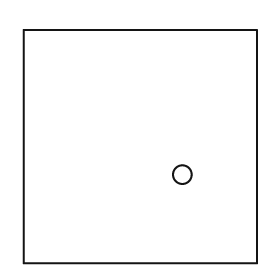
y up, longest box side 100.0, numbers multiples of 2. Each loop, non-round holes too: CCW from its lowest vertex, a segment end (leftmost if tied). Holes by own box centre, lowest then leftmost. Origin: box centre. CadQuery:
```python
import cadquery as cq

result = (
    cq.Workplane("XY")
    .moveTo(-50.0, -50.0)
    .lineTo(50.0, -50.0)
    .lineTo(50.0, 50.0)
    .lineTo(-50.0, 50.0)
    .close()
    .moveTo(18.0, -12.0)
    .circle(4.0)
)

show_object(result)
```